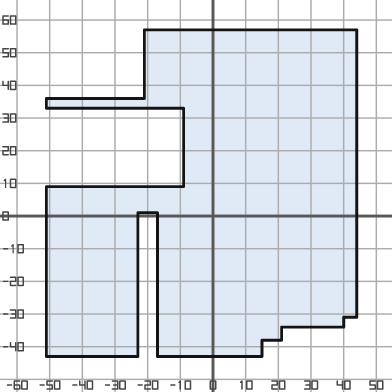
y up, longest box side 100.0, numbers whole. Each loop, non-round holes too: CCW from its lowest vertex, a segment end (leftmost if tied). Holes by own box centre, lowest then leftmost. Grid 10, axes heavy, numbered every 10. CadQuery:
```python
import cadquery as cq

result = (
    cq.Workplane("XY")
    .moveTo(-51.0, -43.0)
    .lineTo(-23.0, -43.0)
    .lineTo(-23.0, 1.0)
    .lineTo(-17.0, 1.0)
    .lineTo(-17.0, -43.0)
    .lineTo(15.0, -43.0)
    .lineTo(15.0, -38.0)
    .lineTo(21.0, -38.0)
    .lineTo(21.0, -34.0)
    .lineTo(40.0, -34.0)
    .lineTo(40.0, -31.0)
    .lineTo(44.0, -31.0)
    .lineTo(44.0, 57.0)
    .lineTo(-21.0, 57.0)
    .lineTo(-21.0, 36.0)
    .lineTo(-51.0, 36.0)
    .lineTo(-51.0, 33.0)
    .lineTo(-9.0, 33.0)
    .lineTo(-9.0, 9.0)
    .lineTo(-51.0, 9.0)
    .close()
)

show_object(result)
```